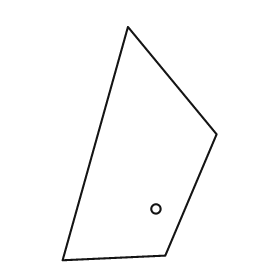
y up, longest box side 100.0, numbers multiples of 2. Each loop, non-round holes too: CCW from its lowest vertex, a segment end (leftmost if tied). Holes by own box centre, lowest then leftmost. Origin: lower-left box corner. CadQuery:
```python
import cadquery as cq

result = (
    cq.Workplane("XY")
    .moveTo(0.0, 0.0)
    .lineTo(44.0, 2.0)
    .lineTo(66.0, 54.0)
    .lineTo(28.0, 100.0)
    .close()
    .moveTo(40.0, 22.0)
    .circle(2.0)
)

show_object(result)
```